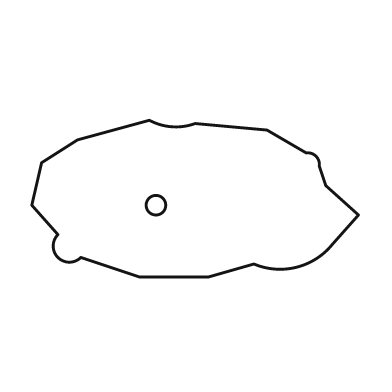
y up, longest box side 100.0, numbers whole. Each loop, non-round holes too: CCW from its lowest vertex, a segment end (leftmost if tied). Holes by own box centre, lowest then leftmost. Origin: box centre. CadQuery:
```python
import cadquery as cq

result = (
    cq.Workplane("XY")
    .moveTo(-17.0, -24.0)
    .lineTo(4.0, -24.0)
    .lineTo(18.0, -20.0)
    .threePointArc((31.0, -21.0), (42.0, -14.0))
    .lineTo(50.0, -5.0)
    .lineTo(40.0, 4.0)
    .lineTo(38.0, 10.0)
    .threePointArc((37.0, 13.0), (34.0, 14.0))
    .lineTo(22.0, 21.0)
    .lineTo(0.0, 23.0)
    .threePointArc((-7.0, 22.0), (-14.0, 24.0))
    .lineTo(-36.0, 18.0)
    .lineTo(-47.0, 11.0)
    .lineTo(-50.0, -2.0)
    .lineTo(-42.0, -11.0)
    .threePointArc((-42.0, -18.0), (-35.0, -18.0))
    .close()
    .moveTo(-12.0, -2.0)
    .circle(3.0)
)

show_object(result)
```